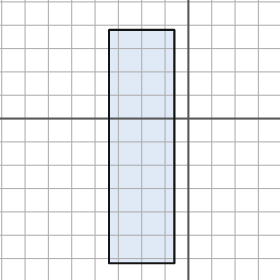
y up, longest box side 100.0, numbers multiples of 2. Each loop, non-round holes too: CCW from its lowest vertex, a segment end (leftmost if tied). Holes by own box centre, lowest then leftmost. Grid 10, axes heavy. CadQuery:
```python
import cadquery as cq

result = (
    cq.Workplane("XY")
    .moveTo(-34.0, -62.0)
    .lineTo(-6.0, -62.0)
    .lineTo(-6.0, 38.0)
    .lineTo(-34.0, 38.0)
    .close()
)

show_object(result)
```